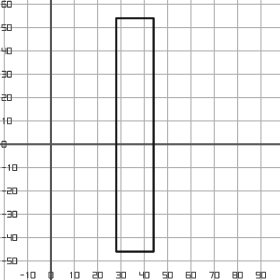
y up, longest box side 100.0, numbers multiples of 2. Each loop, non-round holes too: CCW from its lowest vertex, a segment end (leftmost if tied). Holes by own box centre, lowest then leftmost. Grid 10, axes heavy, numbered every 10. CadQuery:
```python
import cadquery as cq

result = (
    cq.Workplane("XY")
    .moveTo(28.0, -46.0)
    .lineTo(44.0, -46.0)
    .lineTo(44.0, 54.0)
    .lineTo(28.0, 54.0)
    .close()
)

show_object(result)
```